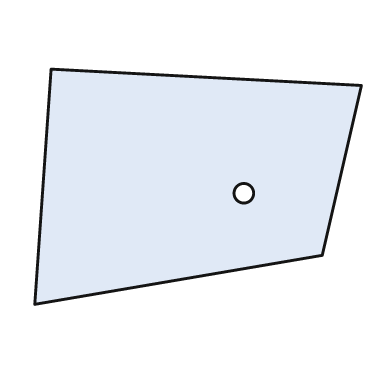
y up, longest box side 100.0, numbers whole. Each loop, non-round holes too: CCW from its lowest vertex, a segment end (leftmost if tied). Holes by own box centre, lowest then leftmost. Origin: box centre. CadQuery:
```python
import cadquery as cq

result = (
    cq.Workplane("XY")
    .moveTo(-50.0, -36.0)
    .lineTo(38.0, -21.0)
    .lineTo(50.0, 31.0)
    .lineTo(-45.0, 36.0)
    .close()
    .moveTo(14.0, -2.0)
    .circle(3.0)
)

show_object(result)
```